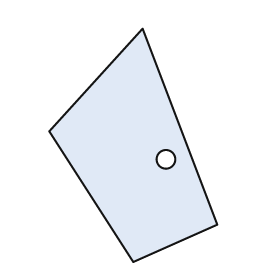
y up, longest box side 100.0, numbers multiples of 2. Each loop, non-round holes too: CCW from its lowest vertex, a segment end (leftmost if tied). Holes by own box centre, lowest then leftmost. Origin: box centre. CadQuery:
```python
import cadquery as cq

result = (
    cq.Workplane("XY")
    .moveTo(0.0, -50.0)
    .lineTo(36.0, -34.0)
    .lineTo(4.0, 50.0)
    .lineTo(-36.0, 6.0)
    .close()
    .moveTo(14.0, -6.0)
    .circle(4.0)
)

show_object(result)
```